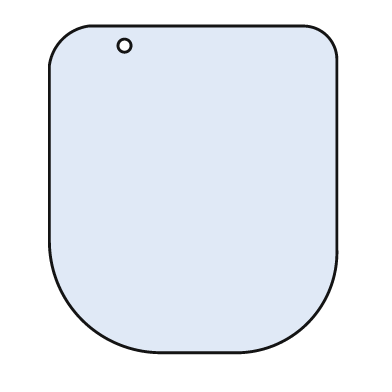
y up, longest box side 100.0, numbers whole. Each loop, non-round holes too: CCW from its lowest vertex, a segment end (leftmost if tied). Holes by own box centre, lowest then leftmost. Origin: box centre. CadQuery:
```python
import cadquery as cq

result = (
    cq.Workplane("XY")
    .moveTo(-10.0, -50.0)
    .lineTo(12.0, -50.0)
    .threePointArc((35.0, -41.0), (44.0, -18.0))
    .lineTo(44.0, 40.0)
    .threePointArc((41.0, 47.0), (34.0, 50.0))
    .lineTo(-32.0, 50.0)
    .threePointArc((-40.0, 46.0), (-44.0, 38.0))
    .lineTo(-44.0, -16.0)
    .threePointArc((-34.0, -40.0), (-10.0, -50.0))
    .close()
    .moveTo(-21.0, 44.0)
    .circle(2.0)
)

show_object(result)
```